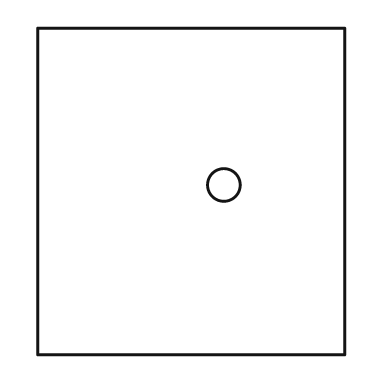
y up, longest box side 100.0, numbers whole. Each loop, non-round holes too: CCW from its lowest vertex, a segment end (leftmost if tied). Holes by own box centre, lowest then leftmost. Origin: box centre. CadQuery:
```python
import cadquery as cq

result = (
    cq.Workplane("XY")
    .moveTo(-47.0, -50.0)
    .lineTo(47.0, -50.0)
    .lineTo(47.0, 50.0)
    .lineTo(-47.0, 50.0)
    .close()
    .moveTo(10.0, 2.0)
    .circle(5.0)
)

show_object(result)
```